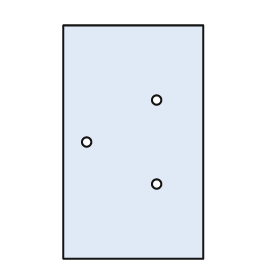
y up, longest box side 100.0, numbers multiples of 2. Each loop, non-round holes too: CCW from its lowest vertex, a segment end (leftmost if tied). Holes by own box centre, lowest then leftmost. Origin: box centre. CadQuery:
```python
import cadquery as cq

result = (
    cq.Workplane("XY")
    .moveTo(-30.0, -50.0)
    .lineTo(30.0, -50.0)
    .lineTo(30.0, 50.0)
    .lineTo(-30.0, 50.0)
    .close()
    .moveTo(10.0, -18.0)
    .circle(2.0)
    .moveTo(-20.0, 0.0)
    .circle(2.0)
    .moveTo(10.0, 18.0)
    .circle(2.0)
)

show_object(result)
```